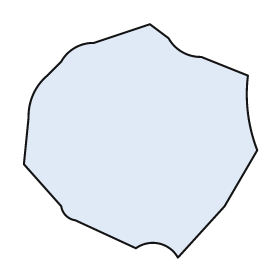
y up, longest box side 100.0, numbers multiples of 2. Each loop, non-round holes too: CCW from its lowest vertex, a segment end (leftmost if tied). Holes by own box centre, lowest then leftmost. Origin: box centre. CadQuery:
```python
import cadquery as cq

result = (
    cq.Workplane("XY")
    .moveTo(16.0, -50.0)
    .lineTo(36.0, -28.0)
    .lineTo(50.0, -4.0)
    .threePointArc((46.0, 12.0), (46.0, 28.0))
    .lineTo(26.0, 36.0)
    .threePointArc((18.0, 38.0), (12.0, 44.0))
    .lineTo(4.0, 50.0)
    .lineTo(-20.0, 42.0)
    .threePointArc((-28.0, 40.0), (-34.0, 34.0))
    .lineTo(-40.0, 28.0)
    .threePointArc((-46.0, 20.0), (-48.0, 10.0))
    .lineTo(-50.0, -10.0)
    .lineTo(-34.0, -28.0)
    .threePointArc((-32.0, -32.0), (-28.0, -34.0))
    .lineTo(-2.0, -46.0)
    .threePointArc((8.0, -44.0), (16.0, -50.0))
    .close()
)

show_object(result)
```